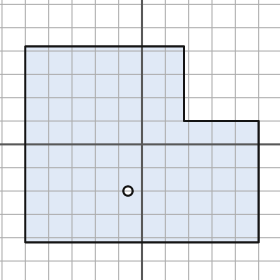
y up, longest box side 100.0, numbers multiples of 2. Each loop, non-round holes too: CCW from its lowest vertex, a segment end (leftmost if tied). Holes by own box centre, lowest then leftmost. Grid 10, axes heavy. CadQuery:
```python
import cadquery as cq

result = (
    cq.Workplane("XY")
    .moveTo(-50.0, -42.0)
    .lineTo(50.0, -42.0)
    .lineTo(50.0, 10.0)
    .lineTo(18.0, 10.0)
    .lineTo(18.0, 42.0)
    .lineTo(-50.0, 42.0)
    .close()
    .moveTo(-6.0, -20.0)
    .circle(2.0)
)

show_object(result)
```